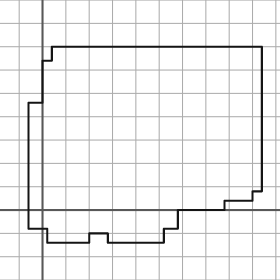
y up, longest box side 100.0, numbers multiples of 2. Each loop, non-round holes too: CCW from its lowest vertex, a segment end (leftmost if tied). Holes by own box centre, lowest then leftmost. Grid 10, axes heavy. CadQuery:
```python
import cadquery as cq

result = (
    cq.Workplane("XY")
    .moveTo(2.0, -14.0)
    .lineTo(20.0, -14.0)
    .lineTo(20.0, -10.0)
    .lineTo(28.0, -10.0)
    .lineTo(28.0, -14.0)
    .lineTo(52.0, -14.0)
    .lineTo(52.0, -8.0)
    .lineTo(58.0, -8.0)
    .lineTo(58.0, 0.0)
    .lineTo(78.0, 0.0)
    .lineTo(78.0, 4.0)
    .lineTo(90.0, 4.0)
    .lineTo(90.0, 8.0)
    .lineTo(94.0, 8.0)
    .lineTo(94.0, 70.0)
    .lineTo(4.0, 70.0)
    .lineTo(4.0, 64.0)
    .lineTo(0.0, 64.0)
    .lineTo(0.0, 46.0)
    .lineTo(-6.0, 46.0)
    .lineTo(-6.0, -8.0)
    .lineTo(2.0, -8.0)
    .close()
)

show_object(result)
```